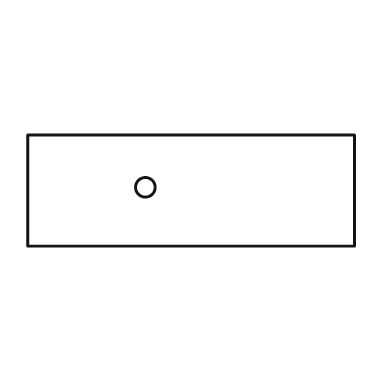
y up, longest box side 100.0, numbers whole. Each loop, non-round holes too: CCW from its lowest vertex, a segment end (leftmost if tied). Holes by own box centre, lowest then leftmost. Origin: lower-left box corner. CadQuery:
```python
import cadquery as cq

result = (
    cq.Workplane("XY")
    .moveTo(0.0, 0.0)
    .lineTo(100.0, 0.0)
    .lineTo(100.0, 34.0)
    .lineTo(0.0, 34.0)
    .close()
    .moveTo(36.0, 18.0)
    .circle(3.0)
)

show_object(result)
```